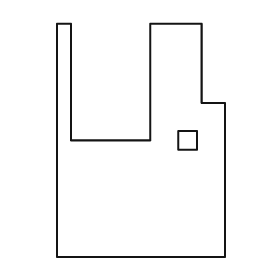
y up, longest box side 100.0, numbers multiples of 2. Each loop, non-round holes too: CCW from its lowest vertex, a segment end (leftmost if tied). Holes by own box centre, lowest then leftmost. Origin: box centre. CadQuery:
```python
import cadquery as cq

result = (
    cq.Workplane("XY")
    .moveTo(-36.0, -50.0)
    .lineTo(36.0, -50.0)
    .lineTo(36.0, 16.0)
    .lineTo(26.0, 16.0)
    .lineTo(26.0, 50.0)
    .lineTo(4.0, 50.0)
    .lineTo(4.0, 0.0)
    .lineTo(-30.0, 0.0)
    .lineTo(-30.0, 50.0)
    .lineTo(-36.0, 50.0)
    .close()
    .moveTo(16.0, -4.0)
    .lineTo(24.0, -4.0)
    .lineTo(24.0, 4.0)
    .lineTo(16.0, 4.0)
    .close()
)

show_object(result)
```